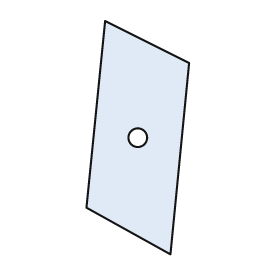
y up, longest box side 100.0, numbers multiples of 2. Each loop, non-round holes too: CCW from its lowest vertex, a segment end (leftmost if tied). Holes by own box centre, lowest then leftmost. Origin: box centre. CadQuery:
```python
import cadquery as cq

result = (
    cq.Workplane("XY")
    .moveTo(14.0, -50.0)
    .lineTo(22.0, 32.0)
    .lineTo(-14.0, 50.0)
    .lineTo(-22.0, -30.0)
    .close()
    .moveTo(0.0, 0.0)
    .circle(4.0)
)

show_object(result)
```